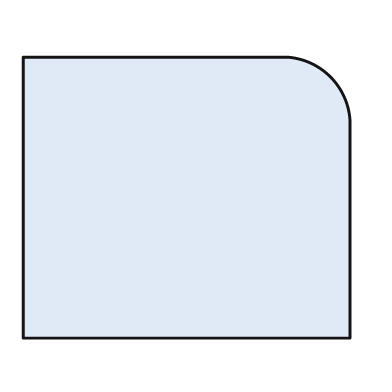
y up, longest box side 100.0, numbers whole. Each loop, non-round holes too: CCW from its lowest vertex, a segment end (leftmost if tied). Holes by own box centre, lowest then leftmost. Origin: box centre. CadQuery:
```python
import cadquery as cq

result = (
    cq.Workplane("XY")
    .moveTo(-50.0, -43.0)
    .lineTo(50.0, -43.0)
    .lineTo(50.0, 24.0)
    .threePointArc((44.0, 37.0), (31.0, 43.0))
    .lineTo(-50.0, 43.0)
    .close()
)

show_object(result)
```